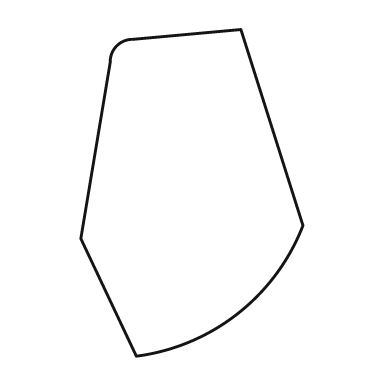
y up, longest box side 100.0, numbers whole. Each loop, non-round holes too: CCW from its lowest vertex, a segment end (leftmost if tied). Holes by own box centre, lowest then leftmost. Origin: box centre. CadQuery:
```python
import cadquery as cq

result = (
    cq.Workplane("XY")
    .moveTo(-17.0, -50.0)
    .threePointArc((14.0, -37.0), (34.0, -10.0))
    .lineTo(15.0, 50.0)
    .lineTo(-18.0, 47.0)
    .threePointArc((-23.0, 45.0), (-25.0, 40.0))
    .lineTo(-34.0, -14.0)
    .close()
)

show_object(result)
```